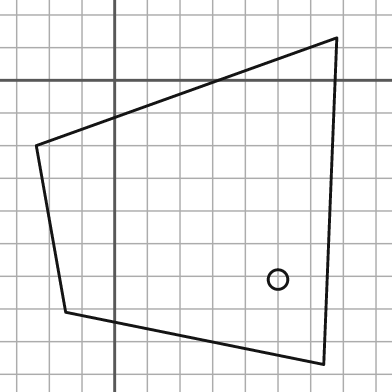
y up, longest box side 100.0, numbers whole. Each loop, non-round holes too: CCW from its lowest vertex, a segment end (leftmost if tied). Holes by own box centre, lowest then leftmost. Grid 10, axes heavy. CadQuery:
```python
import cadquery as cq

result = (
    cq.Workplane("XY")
    .moveTo(64.0, -87.0)
    .lineTo(68.0, 13.0)
    .lineTo(-24.0, -20.0)
    .lineTo(-15.0, -71.0)
    .close()
    .moveTo(50.0, -61.0)
    .circle(3.0)
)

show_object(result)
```